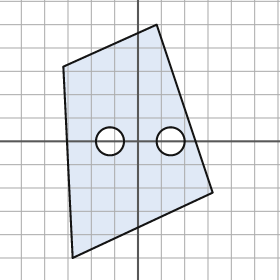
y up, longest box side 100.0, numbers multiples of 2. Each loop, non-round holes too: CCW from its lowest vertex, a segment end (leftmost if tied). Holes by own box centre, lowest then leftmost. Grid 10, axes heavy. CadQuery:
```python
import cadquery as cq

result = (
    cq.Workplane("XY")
    .moveTo(-28.0, -50.0)
    .lineTo(32.0, -22.0)
    .lineTo(8.0, 50.0)
    .lineTo(-32.0, 32.0)
    .close()
    .moveTo(-12.0, 0.0)
    .circle(6.0)
    .moveTo(14.0, 0.0)
    .circle(6.0)
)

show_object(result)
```